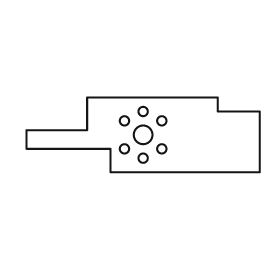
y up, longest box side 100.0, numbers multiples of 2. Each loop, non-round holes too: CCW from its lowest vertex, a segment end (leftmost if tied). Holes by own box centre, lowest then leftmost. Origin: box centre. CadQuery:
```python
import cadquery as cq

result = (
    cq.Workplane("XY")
    .moveTo(-14.0, -16.0)
    .lineTo(50.0, -16.0)
    .lineTo(50.0, 10.0)
    .lineTo(32.0, 10.0)
    .lineTo(32.0, 16.0)
    .lineTo(-24.0, 16.0)
    .lineTo(-24.0, 2.0)
    .lineTo(-50.0, 2.0)
    .lineTo(-50.0, -6.0)
    .lineTo(-14.0, -6.0)
    .close()
    .moveTo(0.0, -10.0)
    .circle(2.0)
    .moveTo(-8.0, -6.0)
    .circle(2.0)
    .moveTo(8.0, -6.0)
    .circle(2.0)
    .moveTo(0.0, 0.0)
    .circle(4.0)
    .moveTo(-8.0, 6.0)
    .circle(2.0)
    .moveTo(8.0, 6.0)
    .circle(2.0)
    .moveTo(0.0, 10.0)
    .circle(2.0)
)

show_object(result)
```